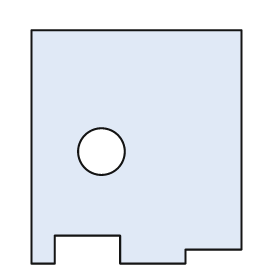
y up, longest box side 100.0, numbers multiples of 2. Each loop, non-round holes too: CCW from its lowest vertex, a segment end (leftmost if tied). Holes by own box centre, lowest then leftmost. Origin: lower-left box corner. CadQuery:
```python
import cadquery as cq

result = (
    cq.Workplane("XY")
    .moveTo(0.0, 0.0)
    .lineTo(10.0, 0.0)
    .lineTo(10.0, 12.0)
    .lineTo(38.0, 12.0)
    .lineTo(38.0, 0.0)
    .lineTo(66.0, 0.0)
    .lineTo(66.0, 6.0)
    .lineTo(90.0, 6.0)
    .lineTo(90.0, 100.0)
    .lineTo(0.0, 100.0)
    .close()
    .moveTo(30.0, 48.0)
    .circle(10.0)
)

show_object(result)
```